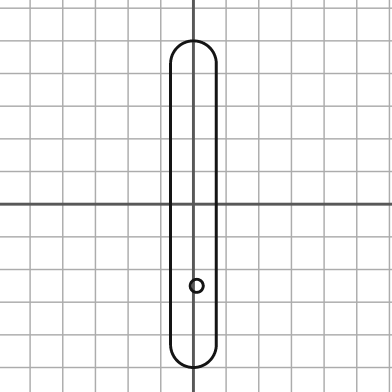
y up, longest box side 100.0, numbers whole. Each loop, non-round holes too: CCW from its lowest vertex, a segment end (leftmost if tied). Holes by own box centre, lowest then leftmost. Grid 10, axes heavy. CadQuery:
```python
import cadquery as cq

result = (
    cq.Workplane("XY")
    .moveTo(-7.0, -43.0)
    .threePointArc((0.0, -50.0), (7.0, -43.0))
    .lineTo(7.0, 43.0)
    .threePointArc((0.0, 50.0), (-7.0, 43.0))
    .close()
    .moveTo(1.0, -25.0)
    .circle(2.0)
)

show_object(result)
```